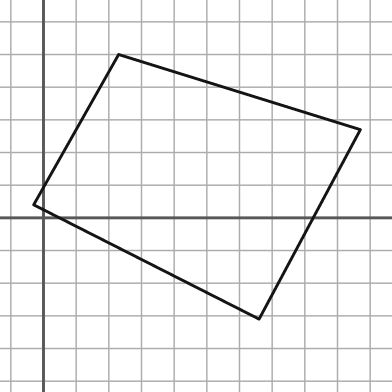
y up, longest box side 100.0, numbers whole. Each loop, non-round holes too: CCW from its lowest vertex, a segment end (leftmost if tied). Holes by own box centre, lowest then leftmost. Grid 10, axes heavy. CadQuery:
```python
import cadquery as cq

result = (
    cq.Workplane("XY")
    .moveTo(66.0, -31.0)
    .lineTo(97.0, 27.0)
    .lineTo(23.0, 50.0)
    .lineTo(-3.0, 4.0)
    .close()
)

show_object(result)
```